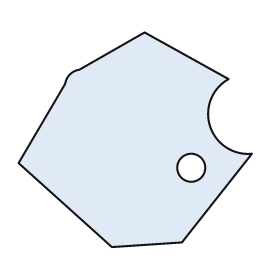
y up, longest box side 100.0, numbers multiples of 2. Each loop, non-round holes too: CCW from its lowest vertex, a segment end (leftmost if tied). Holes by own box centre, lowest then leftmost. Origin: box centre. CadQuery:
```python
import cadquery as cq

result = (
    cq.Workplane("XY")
    .moveTo(-10.0, -46.0)
    .lineTo(20.0, -44.0)
    .lineTo(50.0, -6.0)
    .threePointArc((32.0, 6.0), (40.0, 26.0))
    .lineTo(4.0, 46.0)
    .lineTo(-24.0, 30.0)
    .threePointArc((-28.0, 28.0), (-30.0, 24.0))
    .lineTo(-50.0, -10.0)
    .close()
    .moveTo(24.0, -12.0)
    .circle(6.0)
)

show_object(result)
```